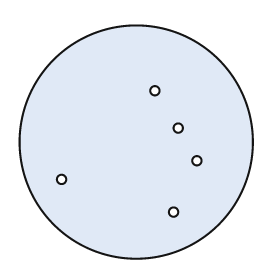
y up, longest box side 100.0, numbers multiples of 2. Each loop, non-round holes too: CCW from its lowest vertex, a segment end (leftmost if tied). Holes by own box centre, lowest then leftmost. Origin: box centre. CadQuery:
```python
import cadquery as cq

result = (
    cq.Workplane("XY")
    .moveTo(0.0, 0.0)
    .circle(50.0)
    .moveTo(16.0, -30.0)
    .circle(2.0)
    .moveTo(-32.0, -16.0)
    .circle(2.0)
    .moveTo(26.0, -8.0)
    .circle(2.0)
    .moveTo(18.0, 6.0)
    .circle(2.0)
    .moveTo(8.0, 22.0)
    .circle(2.0)
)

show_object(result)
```